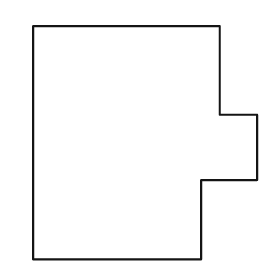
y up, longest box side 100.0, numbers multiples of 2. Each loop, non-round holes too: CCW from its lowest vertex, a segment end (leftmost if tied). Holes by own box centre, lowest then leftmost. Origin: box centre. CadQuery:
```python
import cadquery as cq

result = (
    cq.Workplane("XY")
    .moveTo(-48.0, -50.0)
    .lineTo(24.0, -50.0)
    .lineTo(24.0, -16.0)
    .lineTo(48.0, -16.0)
    .lineTo(48.0, 12.0)
    .lineTo(32.0, 12.0)
    .lineTo(32.0, 50.0)
    .lineTo(-48.0, 50.0)
    .close()
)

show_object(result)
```